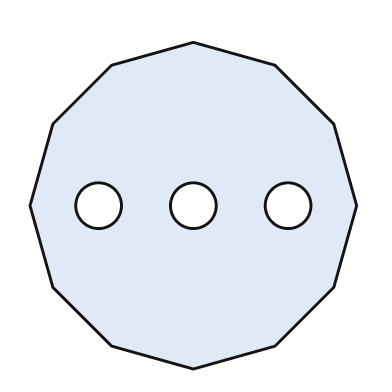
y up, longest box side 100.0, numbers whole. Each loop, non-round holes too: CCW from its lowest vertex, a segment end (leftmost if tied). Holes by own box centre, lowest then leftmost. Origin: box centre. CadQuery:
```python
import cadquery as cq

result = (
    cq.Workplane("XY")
    .moveTo(0.0, -50.0)
    .lineTo(25.0, -43.0)
    .lineTo(43.0, -25.0)
    .lineTo(50.0, 0.0)
    .lineTo(43.0, 25.0)
    .lineTo(25.0, 43.0)
    .lineTo(0.0, 50.0)
    .lineTo(-25.0, 43.0)
    .lineTo(-43.0, 25.0)
    .lineTo(-50.0, 0.0)
    .lineTo(-43.0, -25.0)
    .lineTo(-25.0, -43.0)
    .close()
    .moveTo(-29.0, 0.0)
    .circle(7.0)
    .moveTo(0.0, 0.0)
    .circle(7.0)
    .moveTo(29.0, 0.0)
    .circle(7.0)
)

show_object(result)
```